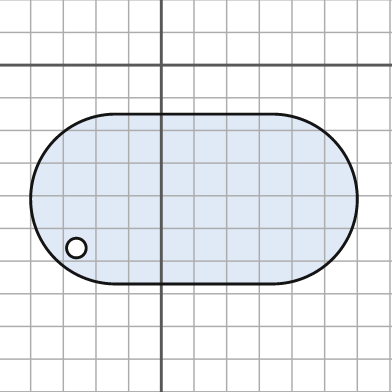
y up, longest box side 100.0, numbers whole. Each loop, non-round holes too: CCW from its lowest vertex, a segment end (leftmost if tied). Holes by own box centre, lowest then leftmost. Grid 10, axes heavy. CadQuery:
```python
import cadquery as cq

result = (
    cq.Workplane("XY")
    .moveTo(-14.0, -67.0)
    .lineTo(34.0, -67.0)
    .threePointArc((60.0, -41.0), (34.0, -15.0))
    .lineTo(-14.0, -15.0)
    .threePointArc((-40.0, -41.0), (-14.0, -67.0))
    .close()
    .moveTo(-26.0, -56.0)
    .circle(3.0)
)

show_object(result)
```